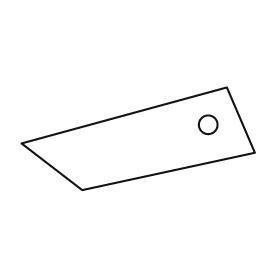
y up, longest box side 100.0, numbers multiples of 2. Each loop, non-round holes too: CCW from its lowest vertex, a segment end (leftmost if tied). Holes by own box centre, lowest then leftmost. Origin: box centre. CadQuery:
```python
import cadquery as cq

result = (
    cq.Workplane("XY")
    .moveTo(-24.0, -22.0)
    .lineTo(50.0, -6.0)
    .lineTo(38.0, 22.0)
    .lineTo(-50.0, -2.0)
    .close()
    .moveTo(30.0, 6.0)
    .circle(4.0)
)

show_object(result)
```